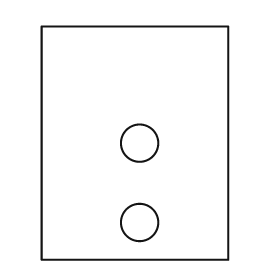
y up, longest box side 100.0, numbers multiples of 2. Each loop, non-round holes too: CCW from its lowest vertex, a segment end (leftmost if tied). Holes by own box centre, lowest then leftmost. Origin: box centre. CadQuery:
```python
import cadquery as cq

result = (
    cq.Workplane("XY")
    .moveTo(-40.0, -50.0)
    .lineTo(40.0, -50.0)
    .lineTo(40.0, 50.0)
    .lineTo(-40.0, 50.0)
    .close()
    .moveTo(2.0, -34.0)
    .circle(8.0)
    .moveTo(2.0, 0.0)
    .circle(8.0)
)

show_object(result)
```